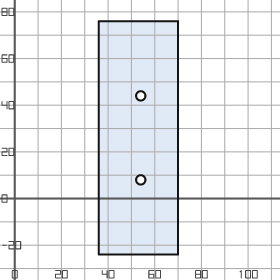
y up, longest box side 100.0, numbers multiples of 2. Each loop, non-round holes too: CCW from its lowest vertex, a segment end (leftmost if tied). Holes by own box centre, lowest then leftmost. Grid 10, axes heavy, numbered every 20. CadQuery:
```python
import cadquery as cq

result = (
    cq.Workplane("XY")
    .moveTo(36.0, -24.0)
    .lineTo(70.0, -24.0)
    .lineTo(70.0, 76.0)
    .lineTo(36.0, 76.0)
    .close()
    .moveTo(54.0, 8.0)
    .circle(2.0)
    .moveTo(54.0, 44.0)
    .circle(2.0)
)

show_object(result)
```